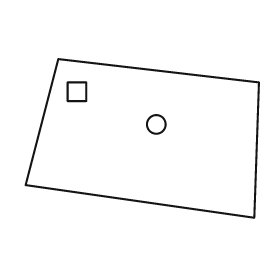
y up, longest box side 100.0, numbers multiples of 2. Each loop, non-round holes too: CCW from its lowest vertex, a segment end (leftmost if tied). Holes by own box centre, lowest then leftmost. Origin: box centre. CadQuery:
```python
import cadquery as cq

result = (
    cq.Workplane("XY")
    .moveTo(48.0, -34.0)
    .lineTo(50.0, 24.0)
    .lineTo(-36.0, 34.0)
    .lineTo(-50.0, -20.0)
    .close()
    .moveTo(6.0, 6.0)
    .circle(4.0)
    .moveTo(-32.0, 16.0)
    .lineTo(-24.0, 16.0)
    .lineTo(-24.0, 24.0)
    .lineTo(-32.0, 24.0)
    .close()
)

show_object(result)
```